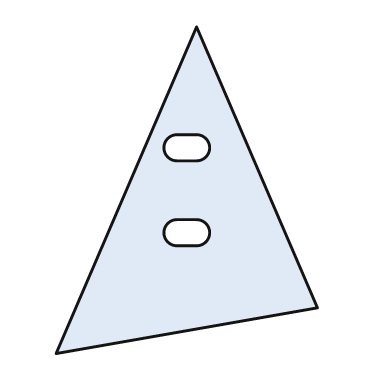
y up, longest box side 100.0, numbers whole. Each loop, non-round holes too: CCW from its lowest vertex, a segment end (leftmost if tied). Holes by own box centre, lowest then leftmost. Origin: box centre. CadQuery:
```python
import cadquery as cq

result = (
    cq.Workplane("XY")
    .moveTo(-40.0, -50.0)
    .lineTo(40.0, -36.0)
    .lineTo(3.0, 50.0)
    .close()
    .moveTo(-3.0, -17.0)
    .lineTo(3.0, -17.0)
    .threePointArc((7.0, -13.0), (3.0, -9.0))
    .lineTo(-3.0, -9.0)
    .threePointArc((-7.0, -13.0), (-3.0, -17.0))
    .close()
    .moveTo(-3.0, 9.0)
    .lineTo(3.0, 9.0)
    .threePointArc((7.0, 13.0), (3.0, 17.0))
    .lineTo(-3.0, 17.0)
    .threePointArc((-7.0, 13.0), (-3.0, 9.0))
    .close()
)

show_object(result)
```